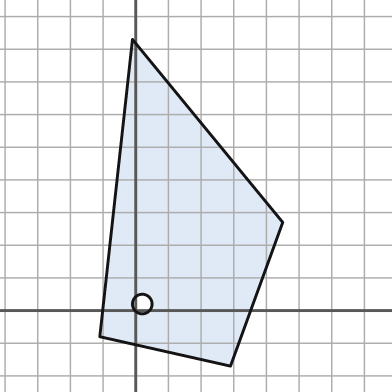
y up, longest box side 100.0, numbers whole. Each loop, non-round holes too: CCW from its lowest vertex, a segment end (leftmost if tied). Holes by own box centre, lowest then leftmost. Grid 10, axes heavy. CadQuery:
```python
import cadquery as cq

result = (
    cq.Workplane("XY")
    .moveTo(29.0, -17.0)
    .lineTo(45.0, 27.0)
    .lineTo(-1.0, 83.0)
    .lineTo(-11.0, -8.0)
    .close()
    .moveTo(2.0, 2.0)
    .circle(3.0)
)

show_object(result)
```